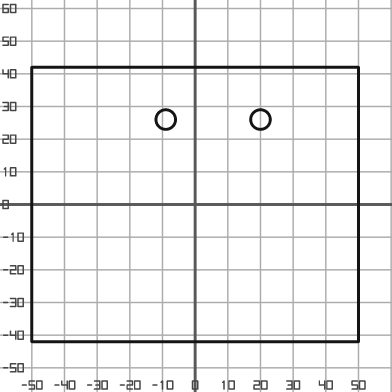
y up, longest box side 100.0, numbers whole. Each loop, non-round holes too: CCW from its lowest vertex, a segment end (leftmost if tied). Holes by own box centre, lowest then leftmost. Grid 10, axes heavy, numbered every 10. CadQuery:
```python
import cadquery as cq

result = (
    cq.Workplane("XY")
    .moveTo(-50.0, -42.0)
    .lineTo(50.0, -42.0)
    .lineTo(50.0, 42.0)
    .lineTo(-50.0, 42.0)
    .close()
    .moveTo(-9.0, 26.0)
    .circle(3.0)
    .moveTo(20.0, 26.0)
    .circle(3.0)
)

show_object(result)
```